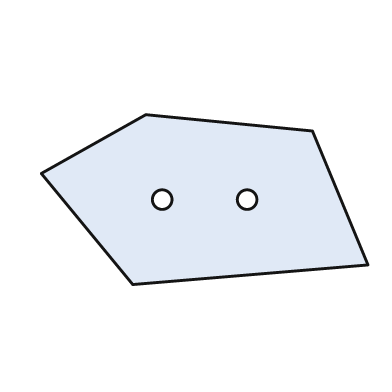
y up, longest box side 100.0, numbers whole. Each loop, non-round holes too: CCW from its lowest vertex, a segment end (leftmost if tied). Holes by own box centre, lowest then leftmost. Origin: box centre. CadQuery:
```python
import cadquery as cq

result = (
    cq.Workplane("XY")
    .moveTo(-22.0, -26.0)
    .lineTo(50.0, -20.0)
    .lineTo(33.0, 21.0)
    .lineTo(-18.0, 26.0)
    .lineTo(-50.0, 8.0)
    .close()
    .moveTo(-13.0, 0.0)
    .circle(3.0)
    .moveTo(13.0, 0.0)
    .circle(3.0)
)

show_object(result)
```